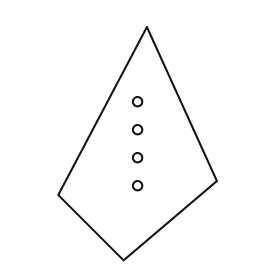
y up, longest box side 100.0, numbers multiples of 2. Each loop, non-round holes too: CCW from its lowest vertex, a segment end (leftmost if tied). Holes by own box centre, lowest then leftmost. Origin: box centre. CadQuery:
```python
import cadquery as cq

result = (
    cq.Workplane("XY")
    .moveTo(-6.0, -50.0)
    .lineTo(34.0, -16.0)
    .lineTo(4.0, 50.0)
    .lineTo(-34.0, -22.0)
    .close()
    .moveTo(0.0, -18.0)
    .circle(2.0)
    .moveTo(0.0, -6.0)
    .circle(2.0)
    .moveTo(0.0, 6.0)
    .circle(2.0)
    .moveTo(0.0, 18.0)
    .circle(2.0)
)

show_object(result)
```